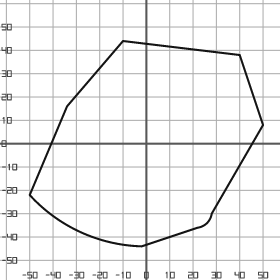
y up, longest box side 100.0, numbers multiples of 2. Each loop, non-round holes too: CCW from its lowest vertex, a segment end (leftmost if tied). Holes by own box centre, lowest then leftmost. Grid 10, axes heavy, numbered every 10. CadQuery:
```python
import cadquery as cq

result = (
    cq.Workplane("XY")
    .moveTo(-2.0, -44.0)
    .lineTo(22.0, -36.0)
    .threePointArc((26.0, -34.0), (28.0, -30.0))
    .lineTo(50.0, 8.0)
    .lineTo(40.0, 38.0)
    .lineTo(-10.0, 44.0)
    .lineTo(-34.0, 16.0)
    .lineTo(-50.0, -22.0)
    .threePointArc((-28.0, -38.0), (-2.0, -44.0))
    .close()
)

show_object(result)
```